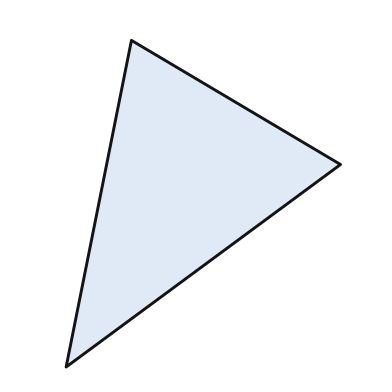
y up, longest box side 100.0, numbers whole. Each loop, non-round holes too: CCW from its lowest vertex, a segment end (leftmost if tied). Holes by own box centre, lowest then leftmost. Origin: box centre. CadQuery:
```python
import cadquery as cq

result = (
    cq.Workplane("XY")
    .moveTo(-42.0, -50.0)
    .lineTo(42.0, 12.0)
    .lineTo(-22.0, 50.0)
    .close()
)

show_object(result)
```